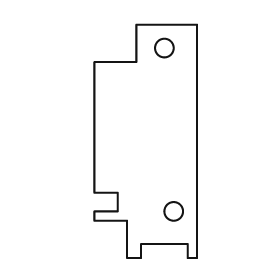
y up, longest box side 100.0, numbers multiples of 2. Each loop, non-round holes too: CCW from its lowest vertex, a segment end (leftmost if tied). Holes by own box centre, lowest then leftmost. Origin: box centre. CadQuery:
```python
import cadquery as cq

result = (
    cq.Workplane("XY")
    .moveTo(-8.0, -50.0)
    .lineTo(-2.0, -50.0)
    .lineTo(-2.0, -44.0)
    .lineTo(18.0, -44.0)
    .lineTo(18.0, -50.0)
    .lineTo(22.0, -50.0)
    .lineTo(22.0, 50.0)
    .lineTo(-4.0, 50.0)
    .lineTo(-4.0, 34.0)
    .lineTo(-22.0, 34.0)
    .lineTo(-22.0, -22.0)
    .lineTo(-12.0, -22.0)
    .lineTo(-12.0, -30.0)
    .lineTo(-22.0, -30.0)
    .lineTo(-22.0, -34.0)
    .lineTo(-8.0, -34.0)
    .close()
    .moveTo(12.0, -30.0)
    .circle(4.0)
    .moveTo(8.0, 40.0)
    .circle(4.0)
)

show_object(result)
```